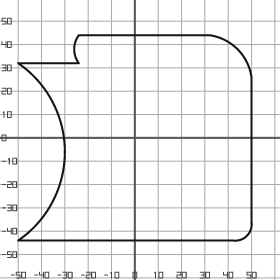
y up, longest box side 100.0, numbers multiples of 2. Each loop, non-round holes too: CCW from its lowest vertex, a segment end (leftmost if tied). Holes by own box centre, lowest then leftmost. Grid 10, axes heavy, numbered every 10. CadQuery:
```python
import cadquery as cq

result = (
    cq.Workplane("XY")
    .moveTo(-50.0, -44.0)
    .lineTo(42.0, -44.0)
    .threePointArc((48.0, -42.0), (50.0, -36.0))
    .lineTo(50.0, 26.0)
    .threePointArc((44.0, 38.0), (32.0, 44.0))
    .lineTo(-24.0, 44.0)
    .threePointArc((-26.0, 38.0), (-24.0, 32.0))
    .lineTo(-50.0, 32.0)
    .threePointArc((-30.0, -6.0), (-50.0, -44.0))
    .close()
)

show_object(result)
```